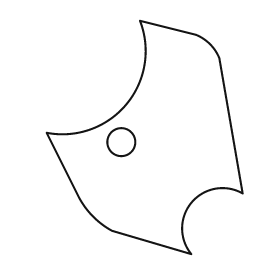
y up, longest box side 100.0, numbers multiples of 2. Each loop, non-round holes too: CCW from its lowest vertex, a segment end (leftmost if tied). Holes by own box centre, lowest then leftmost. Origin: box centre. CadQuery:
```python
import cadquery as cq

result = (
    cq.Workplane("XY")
    .moveTo(20.0, -50.0)
    .threePointArc((20.0, -28.0), (42.0, -24.0))
    .lineTo(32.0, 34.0)
    .threePointArc((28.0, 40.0), (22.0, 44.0))
    .lineTo(-2.0, 50.0)
    .threePointArc((-8.0, 14.0), (-42.0, 2.0))
    .lineTo(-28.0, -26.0)
    .threePointArc((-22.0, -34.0), (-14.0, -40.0))
    .close()
    .moveTo(-10.0, -2.0)
    .circle(6.0)
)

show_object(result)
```